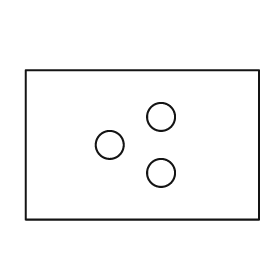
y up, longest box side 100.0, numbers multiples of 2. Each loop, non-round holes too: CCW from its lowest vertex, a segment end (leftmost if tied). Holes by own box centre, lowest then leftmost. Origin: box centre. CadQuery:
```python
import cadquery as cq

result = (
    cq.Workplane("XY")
    .moveTo(-50.0, -32.0)
    .lineTo(50.0, -32.0)
    .lineTo(50.0, 32.0)
    .lineTo(-50.0, 32.0)
    .close()
    .moveTo(8.0, -12.0)
    .circle(6.0)
    .moveTo(-14.0, 0.0)
    .circle(6.0)
    .moveTo(8.0, 12.0)
    .circle(6.0)
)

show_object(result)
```